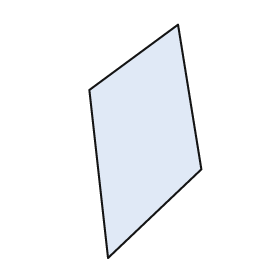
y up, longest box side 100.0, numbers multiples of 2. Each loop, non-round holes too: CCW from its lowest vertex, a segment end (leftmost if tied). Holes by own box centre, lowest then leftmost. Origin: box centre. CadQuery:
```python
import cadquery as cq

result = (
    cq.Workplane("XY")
    .moveTo(-16.0, -50.0)
    .lineTo(24.0, -12.0)
    .lineTo(14.0, 50.0)
    .lineTo(-24.0, 22.0)
    .close()
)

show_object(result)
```